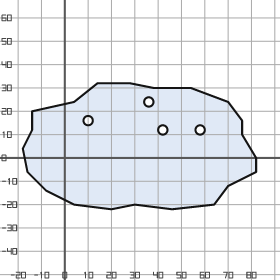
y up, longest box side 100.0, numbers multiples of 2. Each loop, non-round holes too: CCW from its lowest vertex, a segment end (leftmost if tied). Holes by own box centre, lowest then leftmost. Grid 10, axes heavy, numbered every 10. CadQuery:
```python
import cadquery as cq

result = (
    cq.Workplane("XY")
    .moveTo(20.0, -22.0)
    .lineTo(30.0, -20.0)
    .lineTo(46.0, -22.0)
    .lineTo(64.0, -20.0)
    .lineTo(70.0, -12.0)
    .lineTo(82.0, -6.0)
    .lineTo(82.0, 0.0)
    .lineTo(76.0, 10.0)
    .lineTo(76.0, 16.0)
    .lineTo(70.0, 24.0)
    .lineTo(54.0, 30.0)
    .lineTo(38.0, 30.0)
    .lineTo(28.0, 32.0)
    .lineTo(14.0, 32.0)
    .lineTo(4.0, 24.0)
    .lineTo(-14.0, 20.0)
    .lineTo(-14.0, 12.0)
    .lineTo(-18.0, 4.0)
    .lineTo(-16.0, -6.0)
    .lineTo(-8.0, -14.0)
    .lineTo(4.0, -20.0)
    .close()
    .moveTo(42.0, 12.0)
    .circle(2.0)
    .moveTo(58.0, 12.0)
    .circle(2.0)
    .moveTo(10.0, 16.0)
    .circle(2.0)
    .moveTo(36.0, 24.0)
    .circle(2.0)
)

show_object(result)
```